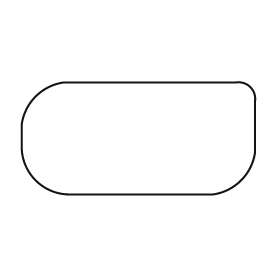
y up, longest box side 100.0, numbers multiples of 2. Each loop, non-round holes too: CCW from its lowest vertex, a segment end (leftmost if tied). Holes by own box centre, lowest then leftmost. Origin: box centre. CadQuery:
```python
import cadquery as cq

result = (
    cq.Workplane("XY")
    .moveTo(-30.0, -24.0)
    .lineTo(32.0, -24.0)
    .threePointArc((44.0, -18.0), (50.0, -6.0))
    .lineTo(50.0, 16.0)
    .threePointArc((48.0, 22.0), (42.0, 24.0))
    .lineTo(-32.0, 24.0)
    .threePointArc((-44.0, 18.0), (-50.0, 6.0))
    .lineTo(-50.0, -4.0)
    .threePointArc((-44.0, -18.0), (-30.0, -24.0))
    .close()
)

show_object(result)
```